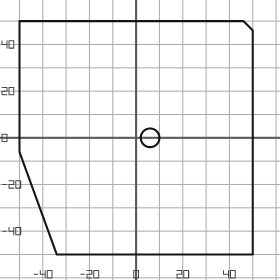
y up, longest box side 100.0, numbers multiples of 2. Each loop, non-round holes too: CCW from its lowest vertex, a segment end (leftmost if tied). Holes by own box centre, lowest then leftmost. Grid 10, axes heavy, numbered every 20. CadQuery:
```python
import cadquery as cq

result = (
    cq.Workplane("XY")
    .moveTo(-34.0, -50.0)
    .lineTo(50.0, -50.0)
    .lineTo(50.0, 46.0)
    .lineTo(46.0, 50.0)
    .lineTo(-50.0, 50.0)
    .lineTo(-50.0, -6.0)
    .close()
    .moveTo(6.0, 0.0)
    .circle(4.0)
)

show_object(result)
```